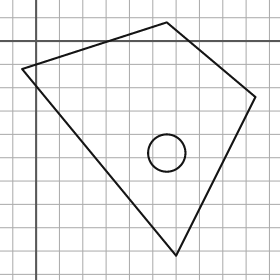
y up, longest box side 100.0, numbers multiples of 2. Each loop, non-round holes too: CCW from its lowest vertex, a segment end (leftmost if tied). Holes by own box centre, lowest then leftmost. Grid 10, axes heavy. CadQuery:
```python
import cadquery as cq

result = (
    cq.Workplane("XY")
    .moveTo(60.0, -92.0)
    .lineTo(94.0, -24.0)
    .lineTo(56.0, 8.0)
    .lineTo(-6.0, -12.0)
    .close()
    .moveTo(56.0, -48.0)
    .circle(8.0)
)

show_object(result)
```